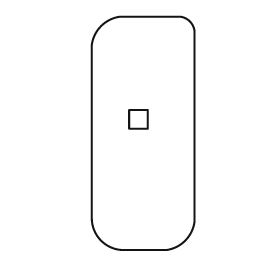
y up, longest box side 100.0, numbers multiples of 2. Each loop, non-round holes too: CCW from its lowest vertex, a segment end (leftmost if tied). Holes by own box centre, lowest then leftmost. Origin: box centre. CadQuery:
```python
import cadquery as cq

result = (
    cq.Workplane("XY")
    .moveTo(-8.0, -50.0)
    .lineTo(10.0, -50.0)
    .threePointArc((18.0, -46.0), (22.0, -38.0))
    .lineTo(22.0, 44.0)
    .threePointArc((20.0, 48.0), (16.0, 50.0))
    .lineTo(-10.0, 50.0)
    .threePointArc((-18.0, 46.0), (-22.0, 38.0))
    .lineTo(-22.0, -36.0)
    .threePointArc((-18.0, -46.0), (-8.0, -50.0))
    .close()
    .moveTo(-6.0, 2.0)
    .lineTo(2.0, 2.0)
    .lineTo(2.0, 10.0)
    .lineTo(-6.0, 10.0)
    .close()
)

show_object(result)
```